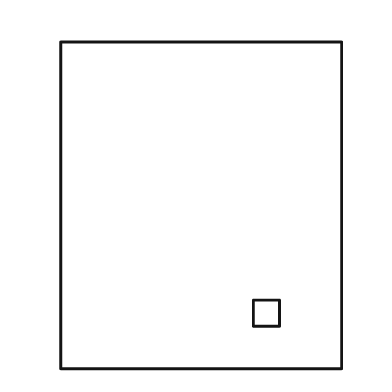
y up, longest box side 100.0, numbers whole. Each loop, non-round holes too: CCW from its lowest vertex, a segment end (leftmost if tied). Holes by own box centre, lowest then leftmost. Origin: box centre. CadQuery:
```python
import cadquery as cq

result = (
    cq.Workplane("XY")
    .moveTo(-43.0, -50.0)
    .lineTo(43.0, -50.0)
    .lineTo(43.0, 50.0)
    .lineTo(-43.0, 50.0)
    .close()
    .moveTo(16.0, -37.0)
    .lineTo(24.0, -37.0)
    .lineTo(24.0, -29.0)
    .lineTo(16.0, -29.0)
    .close()
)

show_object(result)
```